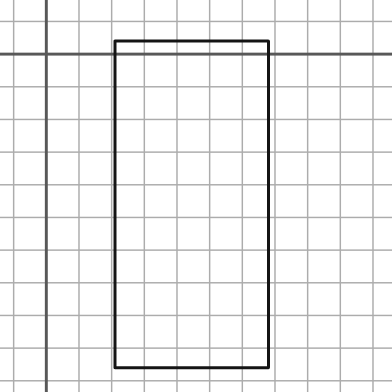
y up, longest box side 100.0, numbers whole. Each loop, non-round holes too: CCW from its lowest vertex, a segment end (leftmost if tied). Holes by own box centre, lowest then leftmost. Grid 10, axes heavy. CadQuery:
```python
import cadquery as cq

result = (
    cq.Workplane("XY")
    .moveTo(21.0, -96.0)
    .lineTo(68.0, -96.0)
    .lineTo(68.0, 4.0)
    .lineTo(21.0, 4.0)
    .close()
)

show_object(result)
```